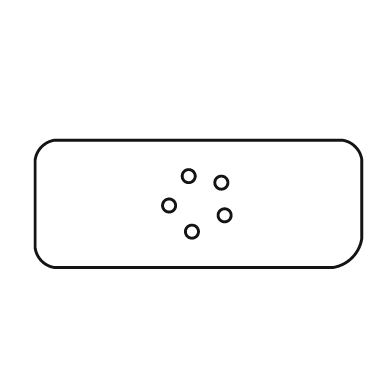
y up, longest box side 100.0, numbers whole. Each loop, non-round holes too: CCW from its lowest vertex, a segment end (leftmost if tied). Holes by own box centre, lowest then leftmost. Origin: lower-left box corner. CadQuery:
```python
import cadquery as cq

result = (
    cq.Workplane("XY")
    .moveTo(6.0, 0.0)
    .lineTo(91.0, 0.0)
    .threePointArc((97.0, 3.0), (100.0, 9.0))
    .lineTo(100.0, 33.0)
    .threePointArc((98.0, 37.0), (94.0, 39.0))
    .lineTo(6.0, 39.0)
    .threePointArc((2.0, 37.0), (0.0, 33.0))
    .lineTo(0.0, 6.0)
    .threePointArc((2.0, 2.0), (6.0, 0.0))
    .close()
    .moveTo(48.0, 11.0)
    .circle(2.0)
    .moveTo(58.0, 16.0)
    .circle(2.0)
    .moveTo(41.0, 19.0)
    .circle(2.0)
    .moveTo(57.0, 26.0)
    .circle(2.0)
    .moveTo(47.0, 28.0)
    .circle(2.0)
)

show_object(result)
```